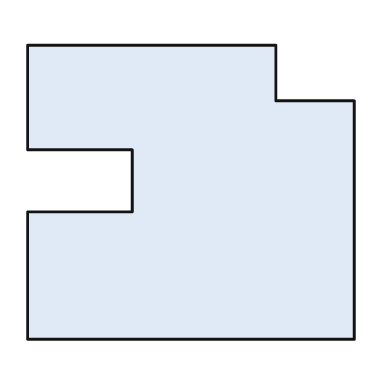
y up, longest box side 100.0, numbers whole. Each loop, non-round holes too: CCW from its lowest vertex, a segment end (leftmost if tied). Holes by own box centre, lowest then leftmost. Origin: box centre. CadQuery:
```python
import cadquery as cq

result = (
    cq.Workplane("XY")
    .moveTo(-50.0, -45.0)
    .lineTo(50.0, -45.0)
    .lineTo(50.0, 28.0)
    .lineTo(26.0, 28.0)
    .lineTo(26.0, 45.0)
    .lineTo(-50.0, 45.0)
    .lineTo(-50.0, 13.0)
    .lineTo(-18.0, 13.0)
    .lineTo(-18.0, -6.0)
    .lineTo(-50.0, -6.0)
    .close()
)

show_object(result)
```